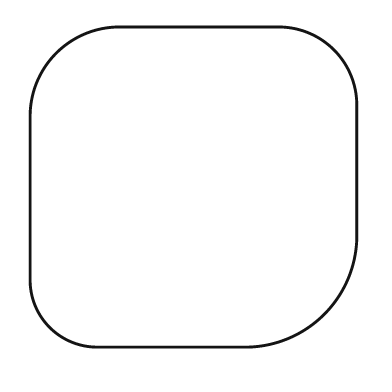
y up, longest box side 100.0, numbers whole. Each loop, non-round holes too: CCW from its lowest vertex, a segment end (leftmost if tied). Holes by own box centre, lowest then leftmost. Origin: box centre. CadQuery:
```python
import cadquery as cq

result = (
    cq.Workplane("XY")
    .moveTo(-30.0, -49.0)
    .lineTo(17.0, -49.0)
    .threePointArc((40.0, -39.0), (50.0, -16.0))
    .lineTo(50.0, 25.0)
    .threePointArc((43.0, 42.0), (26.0, 49.0))
    .lineTo(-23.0, 49.0)
    .threePointArc((-42.0, 41.0), (-50.0, 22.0))
    .lineTo(-50.0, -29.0)
    .threePointArc((-44.0, -43.0), (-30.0, -49.0))
    .close()
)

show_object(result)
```